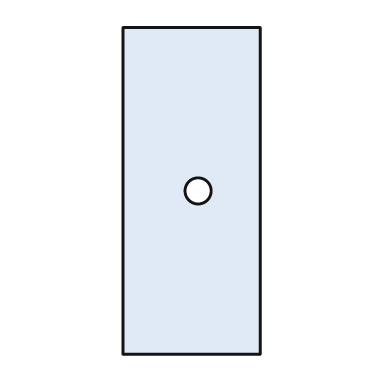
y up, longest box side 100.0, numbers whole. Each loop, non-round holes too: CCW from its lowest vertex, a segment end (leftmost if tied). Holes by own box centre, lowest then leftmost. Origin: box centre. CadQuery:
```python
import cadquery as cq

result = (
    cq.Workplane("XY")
    .moveTo(-21.0, -50.0)
    .lineTo(21.0, -50.0)
    .lineTo(21.0, 50.0)
    .lineTo(-21.0, 50.0)
    .close()
    .moveTo(2.0, 0.0)
    .circle(4.0)
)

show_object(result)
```